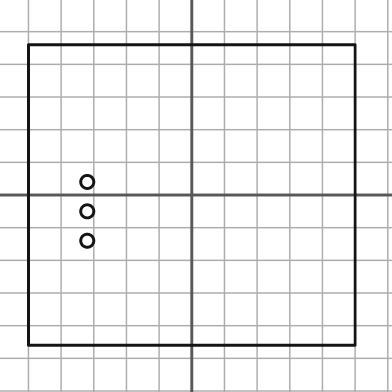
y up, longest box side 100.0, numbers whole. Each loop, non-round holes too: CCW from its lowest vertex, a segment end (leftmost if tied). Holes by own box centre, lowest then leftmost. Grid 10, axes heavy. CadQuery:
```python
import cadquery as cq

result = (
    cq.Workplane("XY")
    .moveTo(-50.0, -46.0)
    .lineTo(50.0, -46.0)
    .lineTo(50.0, 46.0)
    .lineTo(-50.0, 46.0)
    .close()
    .moveTo(-32.0, -14.0)
    .circle(2.0)
    .moveTo(-32.0, -5.0)
    .circle(2.0)
    .moveTo(-32.0, 4.0)
    .circle(2.0)
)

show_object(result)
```